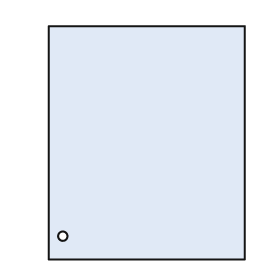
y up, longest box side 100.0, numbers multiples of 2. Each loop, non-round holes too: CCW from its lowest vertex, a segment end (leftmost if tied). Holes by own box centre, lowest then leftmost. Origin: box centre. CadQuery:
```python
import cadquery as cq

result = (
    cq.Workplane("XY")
    .moveTo(-42.0, -50.0)
    .lineTo(42.0, -50.0)
    .lineTo(42.0, 50.0)
    .lineTo(-42.0, 50.0)
    .close()
    .moveTo(-36.0, -40.0)
    .circle(2.0)
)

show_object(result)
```